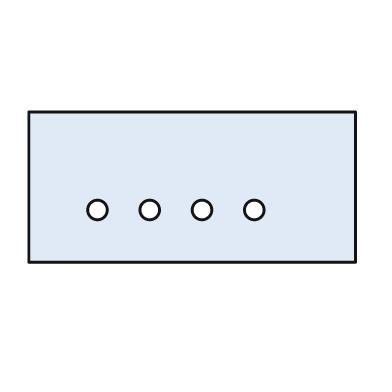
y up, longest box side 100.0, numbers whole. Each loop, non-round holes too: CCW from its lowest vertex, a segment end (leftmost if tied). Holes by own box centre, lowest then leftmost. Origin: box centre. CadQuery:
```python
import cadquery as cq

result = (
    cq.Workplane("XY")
    .moveTo(-50.0, -23.0)
    .lineTo(50.0, -23.0)
    .lineTo(50.0, 23.0)
    .lineTo(-50.0, 23.0)
    .close()
    .moveTo(-29.0, -7.0)
    .circle(3.0)
    .moveTo(-13.0, -7.0)
    .circle(3.0)
    .moveTo(3.0, -7.0)
    .circle(3.0)
    .moveTo(19.0, -7.0)
    .circle(3.0)
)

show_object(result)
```